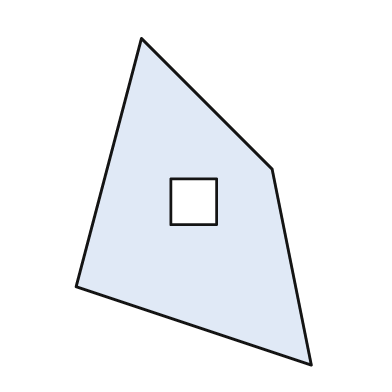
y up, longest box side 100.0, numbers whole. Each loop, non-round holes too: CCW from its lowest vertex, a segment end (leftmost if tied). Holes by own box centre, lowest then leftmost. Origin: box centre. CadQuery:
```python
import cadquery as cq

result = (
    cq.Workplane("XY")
    .moveTo(36.0, -50.0)
    .lineTo(24.0, 10.0)
    .lineTo(-16.0, 50.0)
    .lineTo(-36.0, -26.0)
    .close()
    .moveTo(-7.0, -7.0)
    .lineTo(7.0, -7.0)
    .lineTo(7.0, 7.0)
    .lineTo(-7.0, 7.0)
    .close()
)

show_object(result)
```